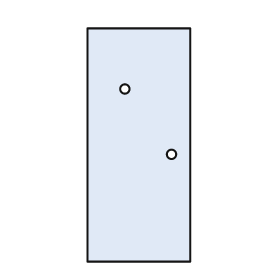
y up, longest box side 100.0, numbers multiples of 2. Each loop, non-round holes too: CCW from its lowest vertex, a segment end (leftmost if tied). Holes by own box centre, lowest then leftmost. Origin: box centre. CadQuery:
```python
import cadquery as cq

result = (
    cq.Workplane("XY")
    .moveTo(-22.0, -50.0)
    .lineTo(22.0, -50.0)
    .lineTo(22.0, 50.0)
    .lineTo(-22.0, 50.0)
    .close()
    .moveTo(14.0, -4.0)
    .circle(2.0)
    .moveTo(-6.0, 24.0)
    .circle(2.0)
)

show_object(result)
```